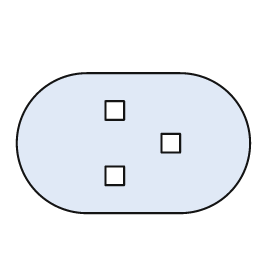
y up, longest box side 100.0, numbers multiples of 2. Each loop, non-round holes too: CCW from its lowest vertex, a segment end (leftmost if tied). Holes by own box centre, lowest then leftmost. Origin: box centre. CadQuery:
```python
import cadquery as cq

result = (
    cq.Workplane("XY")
    .moveTo(-20.0, -30.0)
    .lineTo(20.0, -30.0)
    .threePointArc((50.0, 0.0), (20.0, 30.0))
    .lineTo(-20.0, 30.0)
    .threePointArc((-50.0, 0.0), (-20.0, -30.0))
    .close()
    .moveTo(-12.0, -18.0)
    .lineTo(-4.0, -18.0)
    .lineTo(-4.0, -10.0)
    .lineTo(-12.0, -10.0)
    .close()
    .moveTo(12.0, -4.0)
    .lineTo(20.0, -4.0)
    .lineTo(20.0, 4.0)
    .lineTo(12.0, 4.0)
    .close()
    .moveTo(-12.0, 10.0)
    .lineTo(-4.0, 10.0)
    .lineTo(-4.0, 18.0)
    .lineTo(-12.0, 18.0)
    .close()
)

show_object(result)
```